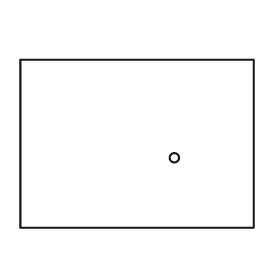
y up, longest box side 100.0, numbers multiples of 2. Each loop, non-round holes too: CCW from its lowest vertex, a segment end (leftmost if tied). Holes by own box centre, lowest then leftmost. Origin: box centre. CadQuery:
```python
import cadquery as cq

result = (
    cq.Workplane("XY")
    .moveTo(-50.0, -36.0)
    .lineTo(50.0, -36.0)
    .lineTo(50.0, 36.0)
    .lineTo(-50.0, 36.0)
    .close()
    .moveTo(16.0, -6.0)
    .circle(2.0)
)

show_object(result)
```